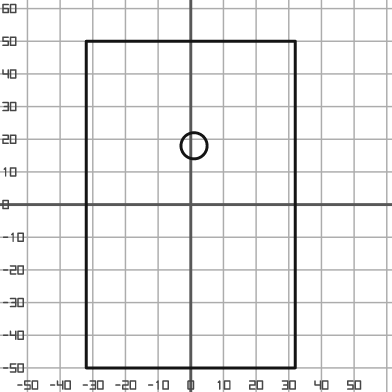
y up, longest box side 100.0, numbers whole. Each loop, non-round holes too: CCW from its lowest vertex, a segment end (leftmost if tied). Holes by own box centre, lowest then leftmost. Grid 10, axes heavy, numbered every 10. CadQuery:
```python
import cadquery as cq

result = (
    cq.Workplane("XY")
    .moveTo(-32.0, -50.0)
    .lineTo(32.0, -50.0)
    .lineTo(32.0, 50.0)
    .lineTo(-32.0, 50.0)
    .close()
    .moveTo(1.0, 18.0)
    .circle(4.0)
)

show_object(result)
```